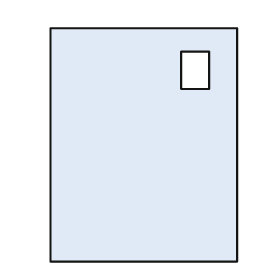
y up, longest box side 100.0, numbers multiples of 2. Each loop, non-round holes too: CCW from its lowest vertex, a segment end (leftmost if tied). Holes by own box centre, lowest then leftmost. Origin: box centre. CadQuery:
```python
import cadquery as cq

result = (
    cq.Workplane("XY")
    .moveTo(-40.0, -50.0)
    .lineTo(40.0, -50.0)
    .lineTo(40.0, 50.0)
    .lineTo(-40.0, 50.0)
    .close()
    .moveTo(16.0, 24.0)
    .lineTo(28.0, 24.0)
    .lineTo(28.0, 40.0)
    .lineTo(16.0, 40.0)
    .close()
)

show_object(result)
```